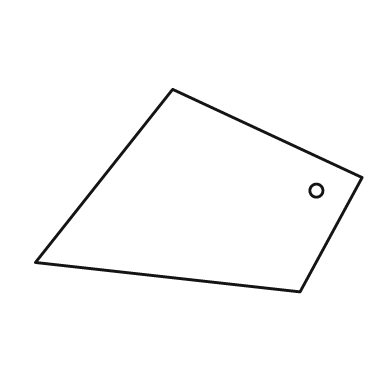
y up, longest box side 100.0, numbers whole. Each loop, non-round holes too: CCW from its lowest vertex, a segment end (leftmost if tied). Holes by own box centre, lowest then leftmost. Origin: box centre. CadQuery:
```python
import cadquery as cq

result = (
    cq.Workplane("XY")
    .moveTo(31.0, -31.0)
    .lineTo(50.0, 4.0)
    .lineTo(-8.0, 31.0)
    .lineTo(-50.0, -22.0)
    .close()
    .moveTo(36.0, 0.0)
    .circle(2.0)
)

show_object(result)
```